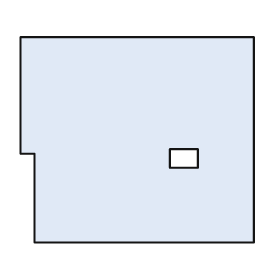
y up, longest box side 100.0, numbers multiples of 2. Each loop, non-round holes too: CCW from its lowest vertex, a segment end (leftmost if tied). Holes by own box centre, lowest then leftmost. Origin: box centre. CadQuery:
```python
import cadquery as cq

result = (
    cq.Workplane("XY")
    .moveTo(-44.0, -44.0)
    .lineTo(50.0, -44.0)
    .lineTo(50.0, 44.0)
    .lineTo(-50.0, 44.0)
    .lineTo(-50.0, -6.0)
    .lineTo(-44.0, -6.0)
    .close()
    .moveTo(14.0, -12.0)
    .lineTo(26.0, -12.0)
    .lineTo(26.0, -4.0)
    .lineTo(14.0, -4.0)
    .close()
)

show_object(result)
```